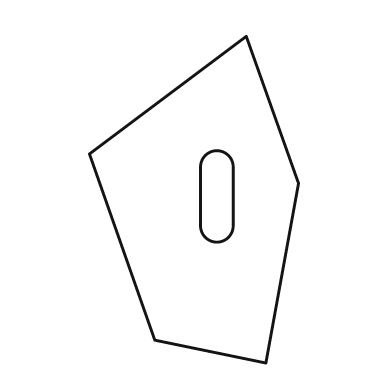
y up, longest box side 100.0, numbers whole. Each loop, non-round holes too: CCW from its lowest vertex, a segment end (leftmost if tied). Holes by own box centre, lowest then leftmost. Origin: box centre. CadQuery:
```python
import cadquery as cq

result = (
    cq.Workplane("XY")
    .moveTo(22.0, -50.0)
    .lineTo(32.0, 5.0)
    .lineTo(16.0, 50.0)
    .lineTo(-32.0, 14.0)
    .lineTo(-12.0, -43.0)
    .close()
    .moveTo(2.0, -8.0)
    .threePointArc((7.0, -13.0), (12.0, -8.0))
    .lineTo(12.0, 10.0)
    .threePointArc((7.0, 15.0), (2.0, 10.0))
    .close()
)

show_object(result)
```